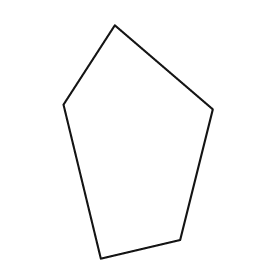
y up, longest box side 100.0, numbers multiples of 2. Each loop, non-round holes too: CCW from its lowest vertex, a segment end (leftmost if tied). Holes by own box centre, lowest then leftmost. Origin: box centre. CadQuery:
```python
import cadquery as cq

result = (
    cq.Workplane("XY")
    .moveTo(-16.0, -50.0)
    .lineTo(18.0, -42.0)
    .lineTo(32.0, 14.0)
    .lineTo(-10.0, 50.0)
    .lineTo(-32.0, 16.0)
    .close()
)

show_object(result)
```